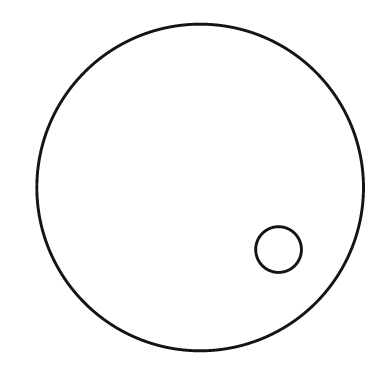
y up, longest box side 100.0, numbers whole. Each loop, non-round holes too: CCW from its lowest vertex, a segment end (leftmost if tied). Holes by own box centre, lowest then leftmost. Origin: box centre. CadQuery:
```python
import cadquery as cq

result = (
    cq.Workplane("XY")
    .moveTo(0.0, 0.0)
    .circle(50.0)
    .moveTo(24.0, -19.0)
    .circle(7.0)
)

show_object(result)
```